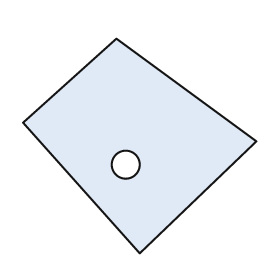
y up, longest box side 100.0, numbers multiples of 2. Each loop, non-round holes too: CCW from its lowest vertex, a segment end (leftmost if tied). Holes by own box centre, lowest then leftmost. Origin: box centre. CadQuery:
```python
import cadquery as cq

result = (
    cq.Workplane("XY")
    .moveTo(0.0, -46.0)
    .lineTo(50.0, 2.0)
    .lineTo(-10.0, 46.0)
    .lineTo(-50.0, 10.0)
    .close()
    .moveTo(-6.0, -8.0)
    .circle(6.0)
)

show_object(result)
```